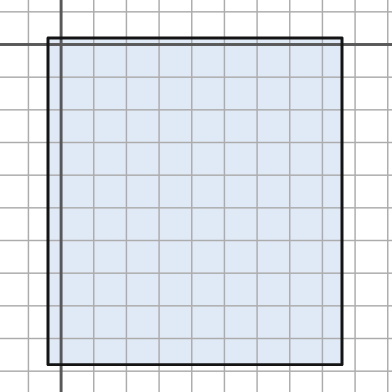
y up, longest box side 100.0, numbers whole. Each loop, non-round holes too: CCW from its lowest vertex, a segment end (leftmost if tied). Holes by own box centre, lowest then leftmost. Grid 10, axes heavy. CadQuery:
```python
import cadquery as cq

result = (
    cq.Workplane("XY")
    .moveTo(-4.0, -98.0)
    .lineTo(86.0, -98.0)
    .lineTo(86.0, 2.0)
    .lineTo(-4.0, 2.0)
    .close()
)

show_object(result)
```